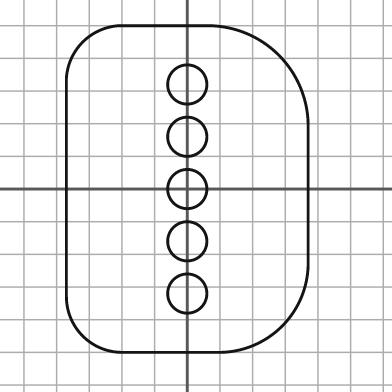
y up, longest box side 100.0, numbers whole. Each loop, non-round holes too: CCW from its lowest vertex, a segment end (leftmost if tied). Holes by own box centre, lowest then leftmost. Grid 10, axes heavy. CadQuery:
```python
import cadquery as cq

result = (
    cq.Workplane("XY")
    .moveTo(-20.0, -50.0)
    .lineTo(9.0, -50.0)
    .threePointArc((29.0, -42.0), (37.0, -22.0))
    .lineTo(37.0, 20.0)
    .threePointArc((28.0, 41.0), (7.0, 50.0))
    .lineTo(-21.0, 50.0)
    .threePointArc((-32.0, 45.0), (-37.0, 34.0))
    .lineTo(-37.0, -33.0)
    .threePointArc((-32.0, -45.0), (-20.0, -50.0))
    .close()
    .moveTo(0.0, -32.0)
    .circle(6.0)
    .moveTo(0.0, -16.0)
    .circle(6.0)
    .moveTo(0.0, 0.0)
    .circle(6.0)
    .moveTo(0.0, 16.0)
    .circle(6.0)
    .moveTo(0.0, 32.0)
    .circle(6.0)
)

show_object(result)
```